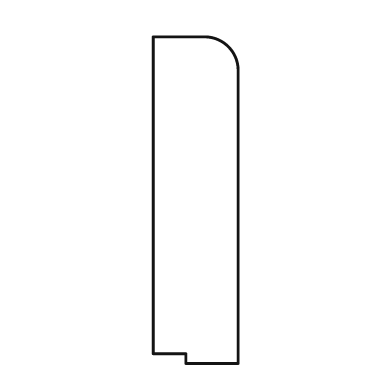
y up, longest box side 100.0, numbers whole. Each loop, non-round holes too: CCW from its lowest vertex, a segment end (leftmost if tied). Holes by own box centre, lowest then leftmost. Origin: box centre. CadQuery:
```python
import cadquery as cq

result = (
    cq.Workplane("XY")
    .moveTo(-3.0, -50.0)
    .lineTo(13.0, -50.0)
    .lineTo(13.0, 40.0)
    .threePointArc((10.0, 47.0), (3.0, 50.0))
    .lineTo(-13.0, 50.0)
    .lineTo(-13.0, -47.0)
    .lineTo(-3.0, -47.0)
    .close()
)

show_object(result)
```